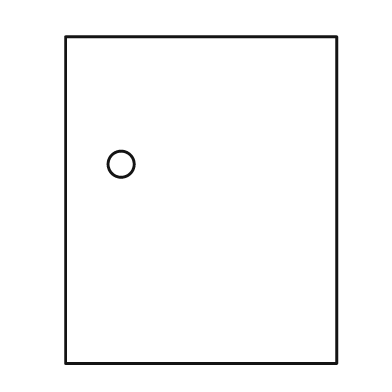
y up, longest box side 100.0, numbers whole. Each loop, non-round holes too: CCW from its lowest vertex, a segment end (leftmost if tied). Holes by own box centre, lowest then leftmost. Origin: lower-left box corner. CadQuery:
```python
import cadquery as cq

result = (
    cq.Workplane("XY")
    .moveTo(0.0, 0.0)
    .lineTo(83.0, 0.0)
    .lineTo(83.0, 100.0)
    .lineTo(0.0, 100.0)
    .close()
    .moveTo(17.0, 61.0)
    .circle(4.0)
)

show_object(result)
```